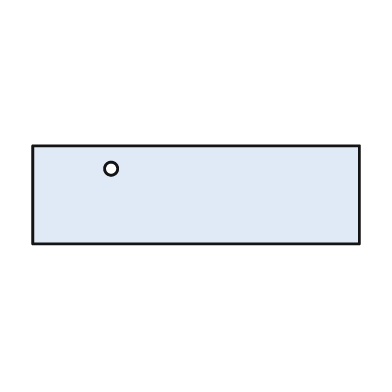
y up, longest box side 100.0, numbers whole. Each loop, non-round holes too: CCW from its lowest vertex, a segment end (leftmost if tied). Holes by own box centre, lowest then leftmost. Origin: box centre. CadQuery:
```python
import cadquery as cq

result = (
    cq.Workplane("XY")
    .moveTo(-50.0, -15.0)
    .lineTo(50.0, -15.0)
    .lineTo(50.0, 15.0)
    .lineTo(-50.0, 15.0)
    .close()
    .moveTo(-26.0, 8.0)
    .circle(2.0)
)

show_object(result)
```